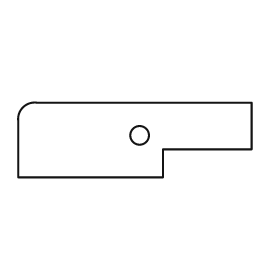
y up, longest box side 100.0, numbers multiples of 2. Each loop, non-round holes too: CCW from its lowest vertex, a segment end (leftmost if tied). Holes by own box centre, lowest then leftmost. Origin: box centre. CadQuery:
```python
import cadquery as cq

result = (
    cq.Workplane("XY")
    .moveTo(-50.0, -16.0)
    .lineTo(12.0, -16.0)
    .lineTo(12.0, -4.0)
    .lineTo(50.0, -4.0)
    .lineTo(50.0, 16.0)
    .lineTo(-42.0, 16.0)
    .threePointArc((-48.0, 14.0), (-50.0, 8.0))
    .close()
    .moveTo(2.0, 2.0)
    .circle(4.0)
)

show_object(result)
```